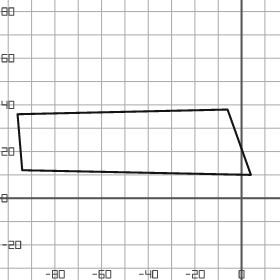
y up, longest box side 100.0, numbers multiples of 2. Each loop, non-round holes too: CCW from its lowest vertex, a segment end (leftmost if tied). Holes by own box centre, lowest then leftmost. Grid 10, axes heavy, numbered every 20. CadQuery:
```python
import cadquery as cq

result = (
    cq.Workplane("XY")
    .moveTo(4.0, 10.0)
    .lineTo(-6.0, 38.0)
    .lineTo(-96.0, 36.0)
    .lineTo(-94.0, 12.0)
    .close()
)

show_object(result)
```